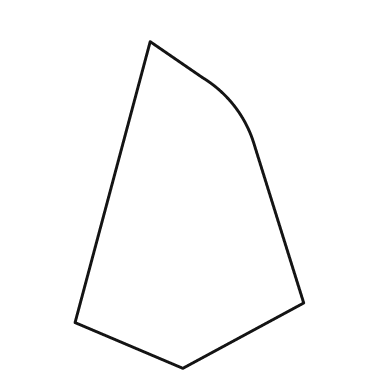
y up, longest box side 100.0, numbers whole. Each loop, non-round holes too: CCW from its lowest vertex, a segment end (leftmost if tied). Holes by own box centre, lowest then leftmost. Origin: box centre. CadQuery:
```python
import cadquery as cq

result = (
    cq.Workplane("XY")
    .moveTo(-2.0, -50.0)
    .lineTo(35.0, -30.0)
    .lineTo(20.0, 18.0)
    .threePointArc((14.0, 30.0), (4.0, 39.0))
    .lineTo(-12.0, 50.0)
    .lineTo(-35.0, -36.0)
    .close()
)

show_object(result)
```